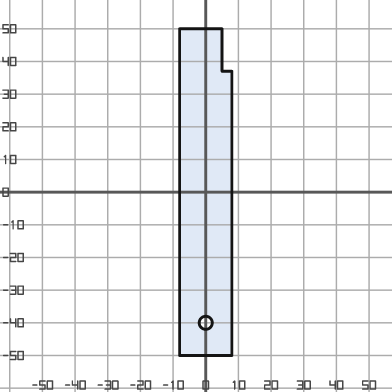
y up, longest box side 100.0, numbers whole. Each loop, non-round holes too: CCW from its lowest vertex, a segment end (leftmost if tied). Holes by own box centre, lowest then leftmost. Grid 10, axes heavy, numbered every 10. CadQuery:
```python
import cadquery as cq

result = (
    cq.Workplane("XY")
    .moveTo(-8.0, -50.0)
    .lineTo(8.0, -50.0)
    .lineTo(8.0, 37.0)
    .lineTo(5.0, 37.0)
    .lineTo(5.0, 50.0)
    .lineTo(-8.0, 50.0)
    .close()
    .moveTo(0.0, -40.0)
    .circle(2.0)
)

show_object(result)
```